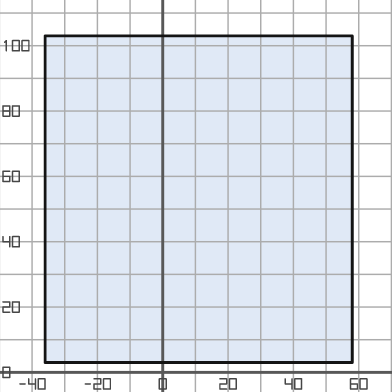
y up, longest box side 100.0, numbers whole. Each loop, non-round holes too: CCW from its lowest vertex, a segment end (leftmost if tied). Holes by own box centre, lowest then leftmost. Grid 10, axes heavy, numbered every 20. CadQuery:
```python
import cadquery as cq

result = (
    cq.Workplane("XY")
    .moveTo(-36.0, 3.0)
    .lineTo(58.0, 3.0)
    .lineTo(58.0, 103.0)
    .lineTo(-36.0, 103.0)
    .close()
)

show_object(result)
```